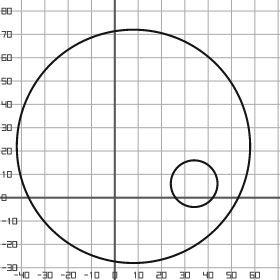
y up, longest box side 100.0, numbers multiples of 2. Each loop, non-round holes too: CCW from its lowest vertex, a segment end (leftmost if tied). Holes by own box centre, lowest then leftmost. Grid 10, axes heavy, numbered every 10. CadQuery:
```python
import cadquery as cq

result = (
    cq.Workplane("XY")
    .moveTo(8.0, 22.0)
    .circle(50.0)
    .moveTo(34.0, 6.0)
    .circle(10.0)
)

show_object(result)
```